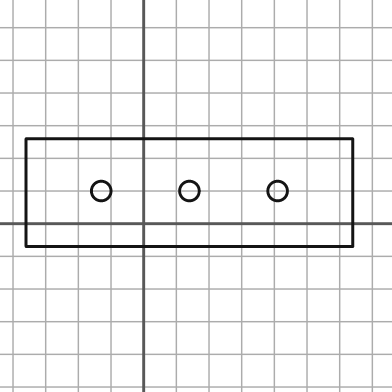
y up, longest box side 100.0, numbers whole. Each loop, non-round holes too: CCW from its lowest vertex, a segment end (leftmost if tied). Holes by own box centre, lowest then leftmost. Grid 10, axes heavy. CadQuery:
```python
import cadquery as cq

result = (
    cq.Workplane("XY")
    .moveTo(-36.0, -7.0)
    .lineTo(64.0, -7.0)
    .lineTo(64.0, 26.0)
    .lineTo(-36.0, 26.0)
    .close()
    .moveTo(-13.0, 10.0)
    .circle(3.0)
    .moveTo(14.0, 10.0)
    .circle(3.0)
    .moveTo(41.0, 10.0)
    .circle(3.0)
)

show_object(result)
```